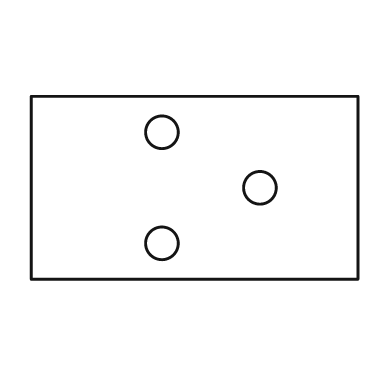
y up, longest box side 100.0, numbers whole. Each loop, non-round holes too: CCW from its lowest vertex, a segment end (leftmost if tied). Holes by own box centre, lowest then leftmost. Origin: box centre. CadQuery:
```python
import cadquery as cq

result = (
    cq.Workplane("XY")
    .moveTo(-50.0, -28.0)
    .lineTo(50.0, -28.0)
    .lineTo(50.0, 28.0)
    .lineTo(-50.0, 28.0)
    .close()
    .moveTo(-10.0, -17.0)
    .circle(5.0)
    .moveTo(20.0, 0.0)
    .circle(5.0)
    .moveTo(-10.0, 17.0)
    .circle(5.0)
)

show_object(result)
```